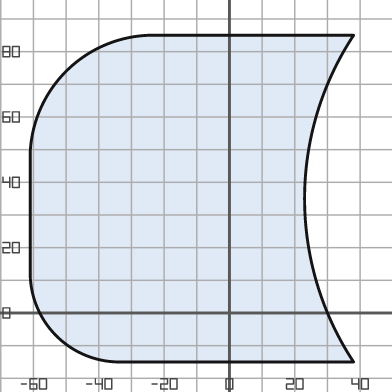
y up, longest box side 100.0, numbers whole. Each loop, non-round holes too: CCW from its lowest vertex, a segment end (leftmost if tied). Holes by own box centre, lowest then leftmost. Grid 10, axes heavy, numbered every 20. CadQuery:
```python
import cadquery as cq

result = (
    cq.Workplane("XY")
    .moveTo(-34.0, -15.0)
    .lineTo(38.0, -15.0)
    .threePointArc((23.0, 35.0), (38.0, 85.0))
    .lineTo(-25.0, 85.0)
    .threePointArc((-50.0, 74.0), (-61.0, 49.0))
    .lineTo(-61.0, 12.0)
    .threePointArc((-53.0, -7.0), (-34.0, -15.0))
    .close()
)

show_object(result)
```